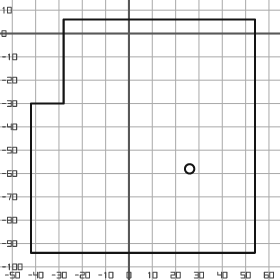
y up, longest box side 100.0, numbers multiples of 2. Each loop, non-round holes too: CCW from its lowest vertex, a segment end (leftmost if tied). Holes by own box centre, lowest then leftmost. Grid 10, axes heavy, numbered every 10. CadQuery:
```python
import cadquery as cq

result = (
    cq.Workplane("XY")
    .moveTo(-42.0, -94.0)
    .lineTo(54.0, -94.0)
    .lineTo(54.0, 6.0)
    .lineTo(-28.0, 6.0)
    .lineTo(-28.0, -30.0)
    .lineTo(-42.0, -30.0)
    .close()
    .moveTo(26.0, -58.0)
    .circle(2.0)
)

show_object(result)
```